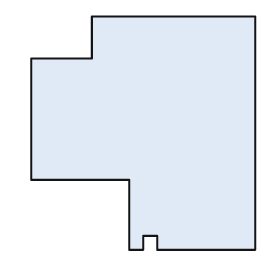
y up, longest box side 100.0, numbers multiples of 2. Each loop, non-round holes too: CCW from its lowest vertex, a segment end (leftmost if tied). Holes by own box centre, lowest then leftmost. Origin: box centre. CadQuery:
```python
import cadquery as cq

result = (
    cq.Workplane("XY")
    .moveTo(-6.0, -50.0)
    .lineTo(0.0, -50.0)
    .lineTo(0.0, -44.0)
    .lineTo(6.0, -44.0)
    .lineTo(6.0, -50.0)
    .lineTo(48.0, -50.0)
    .lineTo(48.0, 50.0)
    .lineTo(-22.0, 50.0)
    .lineTo(-22.0, 32.0)
    .lineTo(-48.0, 32.0)
    .lineTo(-48.0, -20.0)
    .lineTo(-6.0, -20.0)
    .close()
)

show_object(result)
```